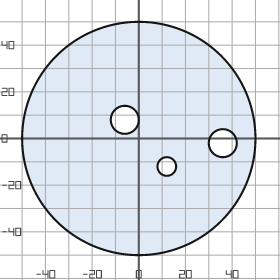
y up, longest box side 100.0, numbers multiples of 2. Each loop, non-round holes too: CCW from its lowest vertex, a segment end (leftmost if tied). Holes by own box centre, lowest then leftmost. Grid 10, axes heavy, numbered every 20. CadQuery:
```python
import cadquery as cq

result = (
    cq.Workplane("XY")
    .moveTo(0.0, 0.0)
    .circle(50.0)
    .moveTo(12.0, -12.0)
    .circle(4.0)
    .moveTo(36.0, -2.0)
    .circle(6.0)
    .moveTo(-6.0, 8.0)
    .circle(6.0)
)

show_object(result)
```